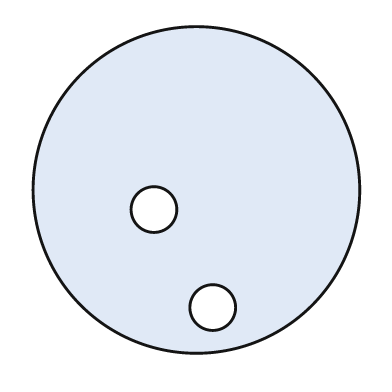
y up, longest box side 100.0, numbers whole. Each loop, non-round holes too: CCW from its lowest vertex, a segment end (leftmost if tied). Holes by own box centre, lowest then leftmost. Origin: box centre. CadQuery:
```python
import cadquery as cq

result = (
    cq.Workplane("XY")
    .moveTo(0.0, 0.0)
    .circle(50.0)
    .moveTo(5.0, -36.0)
    .circle(7.0)
    .moveTo(-13.0, -6.0)
    .circle(7.0)
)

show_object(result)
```